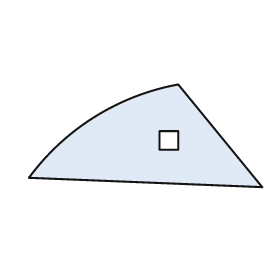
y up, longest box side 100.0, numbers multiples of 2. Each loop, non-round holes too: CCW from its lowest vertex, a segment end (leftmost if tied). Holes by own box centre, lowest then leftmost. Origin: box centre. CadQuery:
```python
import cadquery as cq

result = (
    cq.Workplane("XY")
    .moveTo(50.0, -22.0)
    .lineTo(14.0, 22.0)
    .threePointArc((-22.0, 8.0), (-50.0, -18.0))
    .close()
    .moveTo(6.0, -6.0)
    .lineTo(14.0, -6.0)
    .lineTo(14.0, 2.0)
    .lineTo(6.0, 2.0)
    .close()
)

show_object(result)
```